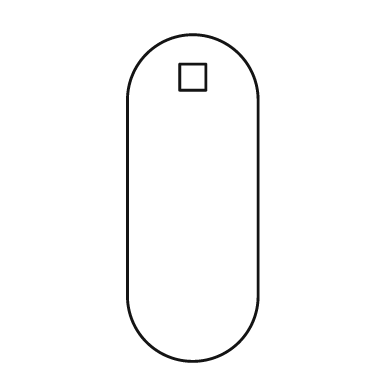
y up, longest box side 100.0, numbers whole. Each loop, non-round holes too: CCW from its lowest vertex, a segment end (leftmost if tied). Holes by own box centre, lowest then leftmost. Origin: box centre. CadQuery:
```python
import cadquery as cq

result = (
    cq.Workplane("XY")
    .moveTo(-20.0, -30.0)
    .threePointArc((0.0, -50.0), (20.0, -30.0))
    .lineTo(20.0, 30.0)
    .threePointArc((0.0, 50.0), (-20.0, 30.0))
    .close()
    .moveTo(-4.0, 33.0)
    .lineTo(4.0, 33.0)
    .lineTo(4.0, 41.0)
    .lineTo(-4.0, 41.0)
    .close()
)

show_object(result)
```